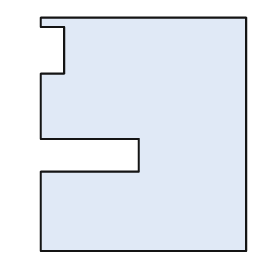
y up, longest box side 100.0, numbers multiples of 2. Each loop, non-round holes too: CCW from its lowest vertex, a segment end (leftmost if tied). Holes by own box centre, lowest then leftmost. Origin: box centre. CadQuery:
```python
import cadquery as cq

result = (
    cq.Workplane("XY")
    .moveTo(-44.0, -50.0)
    .lineTo(44.0, -50.0)
    .lineTo(44.0, 50.0)
    .lineTo(-44.0, 50.0)
    .lineTo(-44.0, 46.0)
    .lineTo(-34.0, 46.0)
    .lineTo(-34.0, 26.0)
    .lineTo(-44.0, 26.0)
    .lineTo(-44.0, -2.0)
    .lineTo(-2.0, -2.0)
    .lineTo(-2.0, -16.0)
    .lineTo(-44.0, -16.0)
    .close()
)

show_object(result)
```